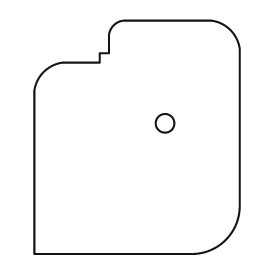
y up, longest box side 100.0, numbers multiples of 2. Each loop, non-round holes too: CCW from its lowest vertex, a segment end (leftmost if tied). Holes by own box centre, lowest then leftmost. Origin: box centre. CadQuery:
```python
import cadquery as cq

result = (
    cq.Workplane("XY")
    .moveTo(-44.0, -50.0)
    .lineTo(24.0, -50.0)
    .threePointArc((38.0, -44.0), (44.0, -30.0))
    .lineTo(44.0, 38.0)
    .threePointArc((40.0, 46.0), (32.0, 50.0))
    .lineTo(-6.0, 50.0)
    .threePointArc((-10.0, 48.0), (-12.0, 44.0))
    .lineTo(-12.0, 36.0)
    .lineTo(-16.0, 36.0)
    .lineTo(-16.0, 32.0)
    .lineTo(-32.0, 32.0)
    .threePointArc((-40.0, 28.0), (-44.0, 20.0))
    .close()
    .moveTo(12.0, 6.0)
    .circle(4.0)
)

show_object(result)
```